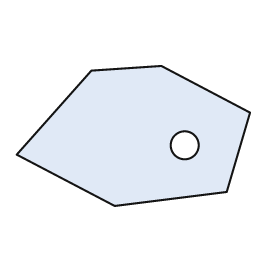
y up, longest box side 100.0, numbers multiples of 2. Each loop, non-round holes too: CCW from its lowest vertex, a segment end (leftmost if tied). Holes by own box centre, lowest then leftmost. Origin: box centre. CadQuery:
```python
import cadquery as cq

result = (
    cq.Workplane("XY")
    .moveTo(-8.0, -30.0)
    .lineTo(40.0, -24.0)
    .lineTo(50.0, 10.0)
    .lineTo(12.0, 30.0)
    .lineTo(-18.0, 28.0)
    .lineTo(-50.0, -8.0)
    .close()
    .moveTo(22.0, -4.0)
    .circle(6.0)
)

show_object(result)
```